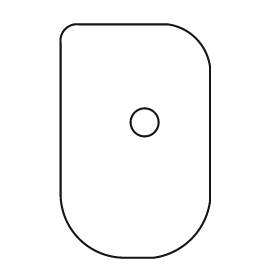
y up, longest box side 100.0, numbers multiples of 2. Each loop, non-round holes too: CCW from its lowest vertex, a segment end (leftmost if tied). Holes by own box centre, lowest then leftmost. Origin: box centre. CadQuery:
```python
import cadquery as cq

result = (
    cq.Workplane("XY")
    .moveTo(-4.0, -50.0)
    .lineTo(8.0, -50.0)
    .threePointArc((24.0, -42.0), (32.0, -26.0))
    .lineTo(32.0, 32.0)
    .threePointArc((26.0, 44.0), (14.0, 50.0))
    .lineTo(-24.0, 50.0)
    .threePointArc((-30.0, 48.0), (-32.0, 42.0))
    .lineTo(-32.0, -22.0)
    .threePointArc((-24.0, -42.0), (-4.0, -50.0))
    .close()
    .moveTo(4.0, 8.0)
    .circle(6.0)
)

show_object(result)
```